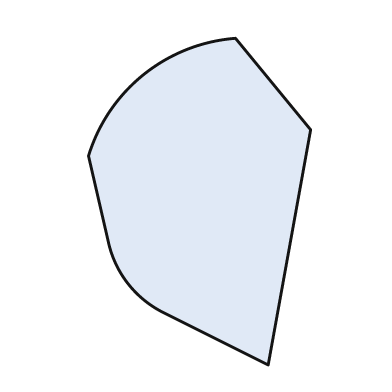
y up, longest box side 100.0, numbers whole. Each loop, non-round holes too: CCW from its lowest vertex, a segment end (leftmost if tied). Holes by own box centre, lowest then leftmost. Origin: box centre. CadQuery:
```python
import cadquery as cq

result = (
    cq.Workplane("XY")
    .moveTo(21.0, -50.0)
    .lineTo(34.0, 22.0)
    .lineTo(11.0, 50.0)
    .threePointArc((-17.0, 39.0), (-34.0, 14.0))
    .lineTo(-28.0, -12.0)
    .threePointArc((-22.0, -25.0), (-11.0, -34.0))
    .close()
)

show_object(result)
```